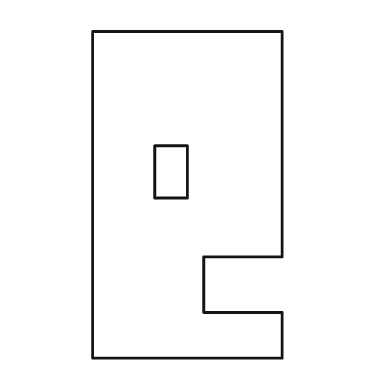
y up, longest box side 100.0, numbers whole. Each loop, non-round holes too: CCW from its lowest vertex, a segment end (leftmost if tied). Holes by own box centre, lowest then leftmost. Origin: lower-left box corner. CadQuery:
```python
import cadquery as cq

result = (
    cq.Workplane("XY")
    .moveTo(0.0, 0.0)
    .lineTo(58.0, 0.0)
    .lineTo(58.0, 14.0)
    .lineTo(34.0, 14.0)
    .lineTo(34.0, 31.0)
    .lineTo(58.0, 31.0)
    .lineTo(58.0, 100.0)
    .lineTo(0.0, 100.0)
    .close()
    .moveTo(19.0, 49.0)
    .lineTo(29.0, 49.0)
    .lineTo(29.0, 65.0)
    .lineTo(19.0, 65.0)
    .close()
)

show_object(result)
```